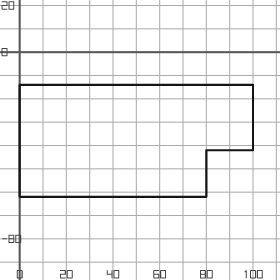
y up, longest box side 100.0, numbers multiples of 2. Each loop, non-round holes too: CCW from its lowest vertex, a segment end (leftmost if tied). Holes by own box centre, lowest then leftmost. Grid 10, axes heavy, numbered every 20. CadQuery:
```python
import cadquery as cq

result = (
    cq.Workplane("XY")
    .moveTo(0.0, -62.0)
    .lineTo(80.0, -62.0)
    .lineTo(80.0, -42.0)
    .lineTo(100.0, -42.0)
    .lineTo(100.0, -14.0)
    .lineTo(0.0, -14.0)
    .close()
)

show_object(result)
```